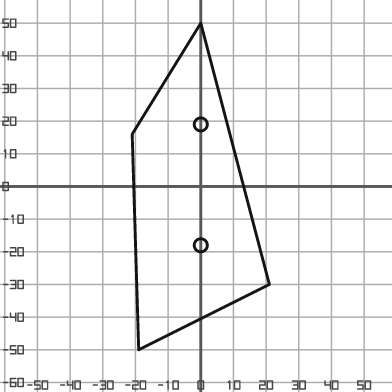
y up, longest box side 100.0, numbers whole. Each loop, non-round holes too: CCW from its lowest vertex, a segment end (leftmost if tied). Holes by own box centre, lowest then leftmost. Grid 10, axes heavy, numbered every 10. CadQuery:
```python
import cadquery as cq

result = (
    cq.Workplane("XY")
    .moveTo(-19.0, -50.0)
    .lineTo(21.0, -30.0)
    .lineTo(0.0, 50.0)
    .lineTo(-21.0, 16.0)
    .close()
    .moveTo(0.0, -18.0)
    .circle(2.0)
    .moveTo(0.0, 19.0)
    .circle(2.0)
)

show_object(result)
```